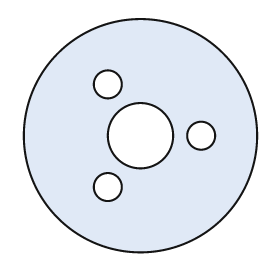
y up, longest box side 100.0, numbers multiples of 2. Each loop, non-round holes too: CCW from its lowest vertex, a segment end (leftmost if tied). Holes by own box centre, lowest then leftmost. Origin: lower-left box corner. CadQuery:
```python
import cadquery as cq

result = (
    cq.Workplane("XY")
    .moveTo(50.0, 50.0)
    .circle(50.0)
    .moveTo(36.0, 28.0)
    .circle(6.0)
    .moveTo(50.0, 50.0)
    .circle(14.0)
    .moveTo(76.0, 50.0)
    .circle(6.0)
    .moveTo(36.0, 72.0)
    .circle(6.0)
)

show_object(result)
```